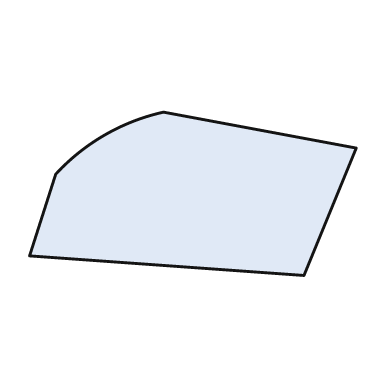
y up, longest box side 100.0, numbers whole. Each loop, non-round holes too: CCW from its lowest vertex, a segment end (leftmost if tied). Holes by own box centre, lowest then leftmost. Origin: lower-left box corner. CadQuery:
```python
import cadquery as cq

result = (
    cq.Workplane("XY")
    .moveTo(84.0, 0.0)
    .lineTo(100.0, 39.0)
    .lineTo(41.0, 50.0)
    .threePointArc((23.0, 43.0), (8.0, 31.0))
    .lineTo(0.0, 6.0)
    .close()
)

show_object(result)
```